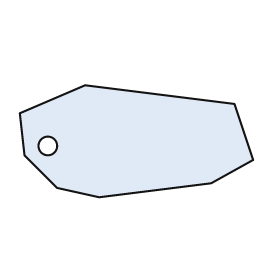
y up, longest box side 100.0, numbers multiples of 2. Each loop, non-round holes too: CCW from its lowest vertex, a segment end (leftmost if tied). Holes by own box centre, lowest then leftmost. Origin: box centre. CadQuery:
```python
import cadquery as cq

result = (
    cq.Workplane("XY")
    .moveTo(-16.0, -24.0)
    .lineTo(32.0, -18.0)
    .lineTo(50.0, -8.0)
    .lineTo(42.0, 16.0)
    .lineTo(-22.0, 24.0)
    .lineTo(-50.0, 12.0)
    .lineTo(-48.0, -6.0)
    .lineTo(-34.0, -20.0)
    .close()
    .moveTo(-38.0, -2.0)
    .circle(4.0)
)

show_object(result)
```